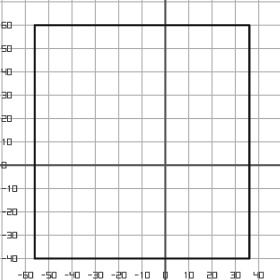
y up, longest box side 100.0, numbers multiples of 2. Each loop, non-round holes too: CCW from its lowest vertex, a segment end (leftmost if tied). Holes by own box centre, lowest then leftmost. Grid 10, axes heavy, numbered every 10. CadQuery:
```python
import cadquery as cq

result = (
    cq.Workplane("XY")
    .moveTo(-56.0, -40.0)
    .lineTo(36.0, -40.0)
    .lineTo(36.0, 60.0)
    .lineTo(-56.0, 60.0)
    .close()
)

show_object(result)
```